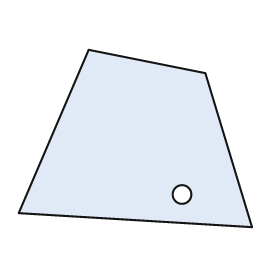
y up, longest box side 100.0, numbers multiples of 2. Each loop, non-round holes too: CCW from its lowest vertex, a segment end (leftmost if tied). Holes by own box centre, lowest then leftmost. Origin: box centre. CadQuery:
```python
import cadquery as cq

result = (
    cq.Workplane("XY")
    .moveTo(50.0, -38.0)
    .lineTo(30.0, 28.0)
    .lineTo(-20.0, 38.0)
    .lineTo(-50.0, -32.0)
    .close()
    .moveTo(20.0, -24.0)
    .circle(4.0)
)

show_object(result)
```